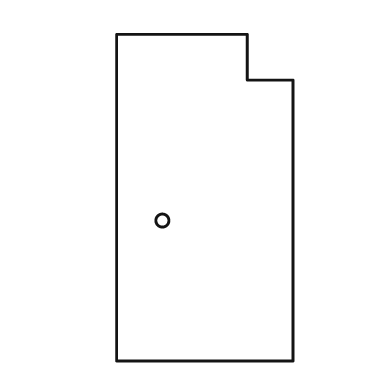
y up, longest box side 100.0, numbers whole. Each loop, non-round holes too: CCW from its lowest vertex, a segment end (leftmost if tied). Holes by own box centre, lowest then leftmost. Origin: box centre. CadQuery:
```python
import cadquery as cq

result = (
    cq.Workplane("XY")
    .moveTo(-27.0, -50.0)
    .lineTo(27.0, -50.0)
    .lineTo(27.0, 36.0)
    .lineTo(13.0, 36.0)
    .lineTo(13.0, 50.0)
    .lineTo(-27.0, 50.0)
    .close()
    .moveTo(-13.0, -7.0)
    .circle(2.0)
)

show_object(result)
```